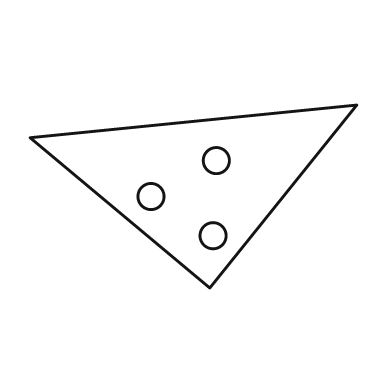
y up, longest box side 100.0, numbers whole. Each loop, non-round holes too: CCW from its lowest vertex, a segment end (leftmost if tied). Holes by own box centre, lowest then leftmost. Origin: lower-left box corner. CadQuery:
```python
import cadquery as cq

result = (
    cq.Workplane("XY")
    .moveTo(55.0, 0.0)
    .lineTo(100.0, 56.0)
    .lineTo(0.0, 46.0)
    .close()
    .moveTo(56.0, 16.0)
    .circle(4.0)
    .moveTo(37.0, 28.0)
    .circle(4.0)
    .moveTo(57.0, 39.0)
    .circle(4.0)
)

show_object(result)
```